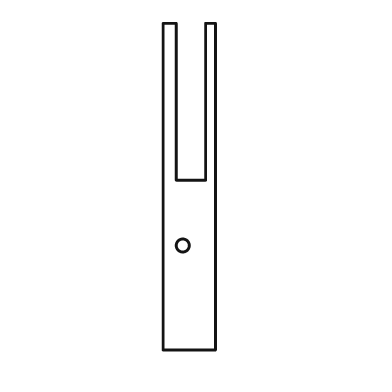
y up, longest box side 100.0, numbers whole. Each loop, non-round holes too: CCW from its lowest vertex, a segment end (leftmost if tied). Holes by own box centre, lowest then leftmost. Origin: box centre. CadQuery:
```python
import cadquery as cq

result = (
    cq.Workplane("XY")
    .moveTo(-8.0, -50.0)
    .lineTo(8.0, -50.0)
    .lineTo(8.0, 50.0)
    .lineTo(5.0, 50.0)
    .lineTo(5.0, 2.0)
    .lineTo(-4.0, 2.0)
    .lineTo(-4.0, 50.0)
    .lineTo(-8.0, 50.0)
    .close()
    .moveTo(-2.0, -18.0)
    .circle(2.0)
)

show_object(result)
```